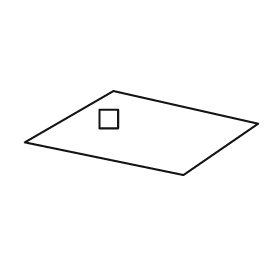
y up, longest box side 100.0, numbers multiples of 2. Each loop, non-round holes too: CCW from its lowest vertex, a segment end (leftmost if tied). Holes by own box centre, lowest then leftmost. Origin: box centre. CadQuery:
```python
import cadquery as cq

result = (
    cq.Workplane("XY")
    .moveTo(18.0, -18.0)
    .lineTo(50.0, 4.0)
    .lineTo(-12.0, 18.0)
    .lineTo(-50.0, -4.0)
    .close()
    .moveTo(-18.0, 2.0)
    .lineTo(-10.0, 2.0)
    .lineTo(-10.0, 10.0)
    .lineTo(-18.0, 10.0)
    .close()
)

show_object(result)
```